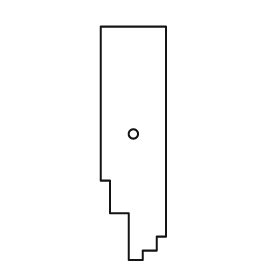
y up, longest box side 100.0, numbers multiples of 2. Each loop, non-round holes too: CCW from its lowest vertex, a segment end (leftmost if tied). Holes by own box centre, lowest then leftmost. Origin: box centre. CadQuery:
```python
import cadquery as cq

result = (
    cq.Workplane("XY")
    .moveTo(-2.0, -50.0)
    .lineTo(4.0, -50.0)
    .lineTo(4.0, -46.0)
    .lineTo(10.0, -46.0)
    .lineTo(10.0, -40.0)
    .lineTo(14.0, -40.0)
    .lineTo(14.0, 50.0)
    .lineTo(-14.0, 50.0)
    .lineTo(-14.0, -16.0)
    .lineTo(-10.0, -16.0)
    .lineTo(-10.0, -30.0)
    .lineTo(-2.0, -30.0)
    .close()
    .moveTo(0.0, 4.0)
    .circle(2.0)
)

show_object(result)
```